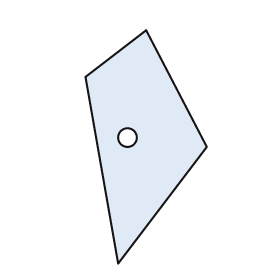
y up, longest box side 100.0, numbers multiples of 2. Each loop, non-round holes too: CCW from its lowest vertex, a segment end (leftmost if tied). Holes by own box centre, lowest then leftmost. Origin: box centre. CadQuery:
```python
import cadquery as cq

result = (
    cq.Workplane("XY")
    .moveTo(-12.0, -50.0)
    .lineTo(26.0, 0.0)
    .lineTo(0.0, 50.0)
    .lineTo(-26.0, 30.0)
    .close()
    .moveTo(-8.0, 4.0)
    .circle(4.0)
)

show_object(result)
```